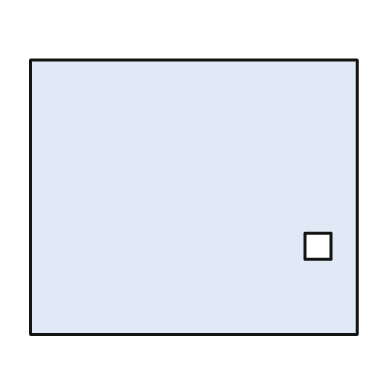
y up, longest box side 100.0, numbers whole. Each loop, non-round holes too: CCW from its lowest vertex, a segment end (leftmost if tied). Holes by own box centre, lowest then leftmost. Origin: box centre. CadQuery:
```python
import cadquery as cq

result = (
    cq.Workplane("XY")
    .moveTo(-50.0, -42.0)
    .lineTo(50.0, -42.0)
    .lineTo(50.0, 42.0)
    .lineTo(-50.0, 42.0)
    .close()
    .moveTo(34.0, -19.0)
    .lineTo(42.0, -19.0)
    .lineTo(42.0, -11.0)
    .lineTo(34.0, -11.0)
    .close()
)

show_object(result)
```